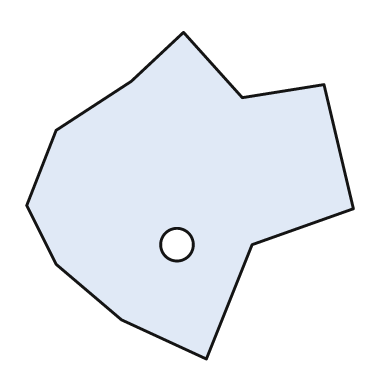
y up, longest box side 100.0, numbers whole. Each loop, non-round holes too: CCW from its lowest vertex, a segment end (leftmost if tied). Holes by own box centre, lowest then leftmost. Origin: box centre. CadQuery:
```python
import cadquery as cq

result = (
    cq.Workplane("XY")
    .moveTo(5.0, -50.0)
    .lineTo(19.0, -15.0)
    .lineTo(50.0, -4.0)
    .lineTo(41.0, 34.0)
    .lineTo(16.0, 30.0)
    .lineTo(-2.0, 50.0)
    .lineTo(-18.0, 35.0)
    .lineTo(-41.0, 20.0)
    .lineTo(-50.0, -3.0)
    .lineTo(-41.0, -21.0)
    .lineTo(-21.0, -38.0)
    .close()
    .moveTo(-4.0, -15.0)
    .circle(5.0)
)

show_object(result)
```